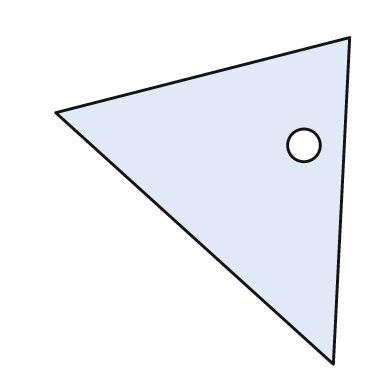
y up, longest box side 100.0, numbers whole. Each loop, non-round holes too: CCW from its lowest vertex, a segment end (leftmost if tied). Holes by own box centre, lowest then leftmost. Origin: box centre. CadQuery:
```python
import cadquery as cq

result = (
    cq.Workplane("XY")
    .moveTo(40.0, -50.0)
    .lineTo(45.0, 50.0)
    .lineTo(-45.0, 27.0)
    .close()
    .moveTo(31.0, 17.0)
    .circle(5.0)
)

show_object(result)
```